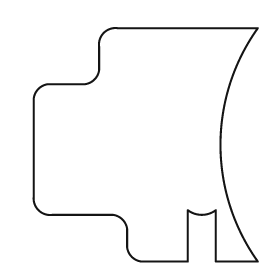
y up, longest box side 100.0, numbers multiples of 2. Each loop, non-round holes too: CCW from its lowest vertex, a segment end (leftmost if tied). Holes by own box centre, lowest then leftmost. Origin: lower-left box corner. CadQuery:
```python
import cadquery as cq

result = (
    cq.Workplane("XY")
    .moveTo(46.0, 0.0)
    .lineTo(66.0, 0.0)
    .lineTo(66.0, 22.0)
    .threePointArc((72.0, 20.0), (78.0, 22.0))
    .lineTo(78.0, 0.0)
    .lineTo(96.0, 0.0)
    .threePointArc((80.0, 50.0), (96.0, 100.0))
    .lineTo(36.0, 100.0)
    .threePointArc((30.0, 98.0), (28.0, 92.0))
    .lineTo(28.0, 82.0)
    .threePointArc((26.0, 78.0), (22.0, 76.0))
    .lineTo(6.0, 76.0)
    .threePointArc((2.0, 74.0), (0.0, 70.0))
    .lineTo(0.0, 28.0)
    .threePointArc((2.0, 22.0), (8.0, 20.0))
    .lineTo(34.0, 20.0)
    .threePointArc((38.0, 18.0), (40.0, 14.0))
    .lineTo(40.0, 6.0)
    .threePointArc((42.0, 2.0), (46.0, 0.0))
    .close()
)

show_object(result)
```